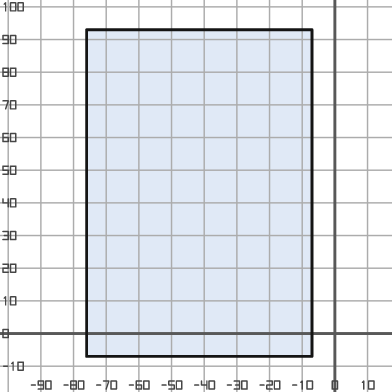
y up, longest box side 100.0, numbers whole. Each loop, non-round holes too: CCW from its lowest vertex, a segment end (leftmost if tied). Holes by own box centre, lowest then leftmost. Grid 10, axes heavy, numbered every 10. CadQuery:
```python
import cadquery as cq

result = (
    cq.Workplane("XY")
    .moveTo(-76.0, -7.0)
    .lineTo(-7.0, -7.0)
    .lineTo(-7.0, 93.0)
    .lineTo(-76.0, 93.0)
    .close()
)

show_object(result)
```